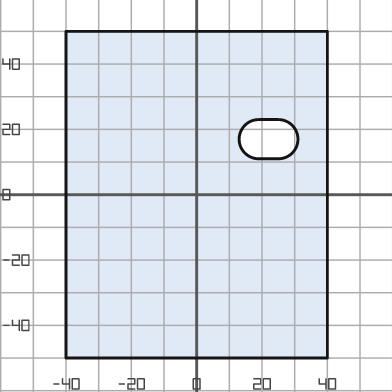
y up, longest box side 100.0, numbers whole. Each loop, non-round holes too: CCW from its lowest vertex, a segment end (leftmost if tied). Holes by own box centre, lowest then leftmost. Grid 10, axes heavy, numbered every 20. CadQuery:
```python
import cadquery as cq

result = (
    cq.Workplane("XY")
    .moveTo(-40.0, -50.0)
    .lineTo(40.0, -50.0)
    .lineTo(40.0, 50.0)
    .lineTo(-40.0, 50.0)
    .close()
    .moveTo(19.0, 11.0)
    .lineTo(25.0, 11.0)
    .threePointArc((31.0, 17.0), (25.0, 23.0))
    .lineTo(19.0, 23.0)
    .threePointArc((13.0, 17.0), (19.0, 11.0))
    .close()
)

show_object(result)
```